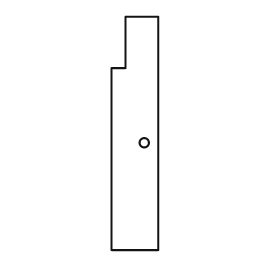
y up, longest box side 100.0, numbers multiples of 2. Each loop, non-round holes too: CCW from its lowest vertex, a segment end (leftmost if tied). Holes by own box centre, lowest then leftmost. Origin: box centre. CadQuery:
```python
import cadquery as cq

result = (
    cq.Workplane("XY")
    .moveTo(-10.0, -50.0)
    .lineTo(10.0, -50.0)
    .lineTo(10.0, 50.0)
    .lineTo(-4.0, 50.0)
    .lineTo(-4.0, 28.0)
    .lineTo(-10.0, 28.0)
    .close()
    .moveTo(4.0, -4.0)
    .circle(2.0)
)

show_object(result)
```